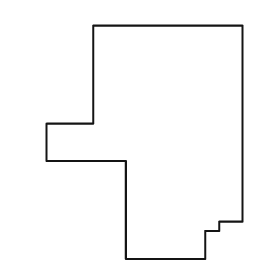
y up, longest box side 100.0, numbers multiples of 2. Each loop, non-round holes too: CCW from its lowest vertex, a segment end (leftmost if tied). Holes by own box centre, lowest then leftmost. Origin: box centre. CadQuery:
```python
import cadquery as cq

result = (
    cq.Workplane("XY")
    .moveTo(-8.0, -50.0)
    .lineTo(26.0, -50.0)
    .lineTo(26.0, -38.0)
    .lineTo(32.0, -38.0)
    .lineTo(32.0, -34.0)
    .lineTo(42.0, -34.0)
    .lineTo(42.0, 50.0)
    .lineTo(-22.0, 50.0)
    .lineTo(-22.0, 8.0)
    .lineTo(-42.0, 8.0)
    .lineTo(-42.0, -8.0)
    .lineTo(-8.0, -8.0)
    .close()
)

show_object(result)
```